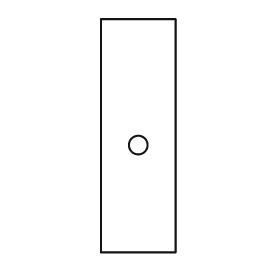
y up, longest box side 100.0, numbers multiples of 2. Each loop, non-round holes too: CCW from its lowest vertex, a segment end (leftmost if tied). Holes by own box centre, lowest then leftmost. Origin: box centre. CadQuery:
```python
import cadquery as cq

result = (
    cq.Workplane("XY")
    .moveTo(-16.0, -50.0)
    .lineTo(16.0, -50.0)
    .lineTo(16.0, 50.0)
    .lineTo(-16.0, 50.0)
    .close()
    .moveTo(0.0, -4.0)
    .circle(4.0)
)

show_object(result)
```